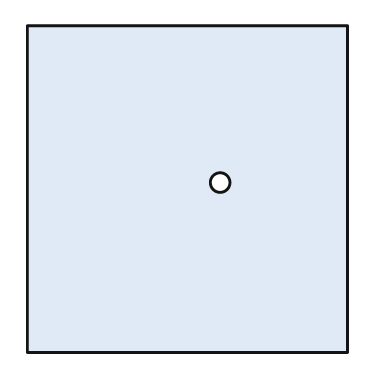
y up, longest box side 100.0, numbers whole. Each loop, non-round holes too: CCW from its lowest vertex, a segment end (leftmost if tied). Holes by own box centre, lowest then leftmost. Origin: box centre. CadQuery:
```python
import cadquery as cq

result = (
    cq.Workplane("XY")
    .moveTo(-49.0, -50.0)
    .lineTo(49.0, -50.0)
    .lineTo(49.0, 50.0)
    .lineTo(-49.0, 50.0)
    .close()
    .moveTo(10.0, 2.0)
    .circle(3.0)
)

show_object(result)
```